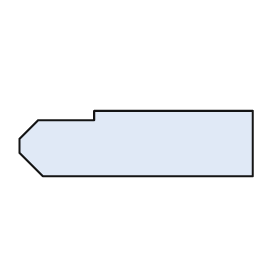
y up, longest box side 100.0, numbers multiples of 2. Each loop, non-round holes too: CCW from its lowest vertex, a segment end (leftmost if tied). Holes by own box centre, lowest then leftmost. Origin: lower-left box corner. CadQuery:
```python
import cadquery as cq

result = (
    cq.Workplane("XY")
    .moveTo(10.0, 0.0)
    .lineTo(100.0, 0.0)
    .lineTo(100.0, 28.0)
    .lineTo(32.0, 28.0)
    .lineTo(32.0, 24.0)
    .lineTo(8.0, 24.0)
    .lineTo(0.0, 16.0)
    .lineTo(0.0, 10.0)
    .close()
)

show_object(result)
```